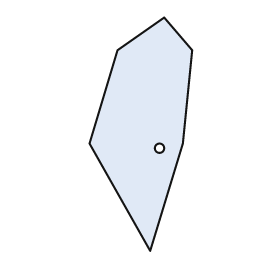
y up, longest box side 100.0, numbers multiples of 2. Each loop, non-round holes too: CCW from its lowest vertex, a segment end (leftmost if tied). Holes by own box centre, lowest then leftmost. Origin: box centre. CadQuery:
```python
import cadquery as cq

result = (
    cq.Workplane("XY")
    .moveTo(4.0, -50.0)
    .lineTo(18.0, -4.0)
    .lineTo(22.0, 36.0)
    .lineTo(10.0, 50.0)
    .lineTo(-10.0, 36.0)
    .lineTo(-22.0, -4.0)
    .close()
    .moveTo(8.0, -6.0)
    .circle(2.0)
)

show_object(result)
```